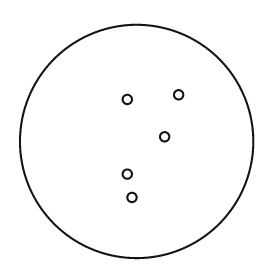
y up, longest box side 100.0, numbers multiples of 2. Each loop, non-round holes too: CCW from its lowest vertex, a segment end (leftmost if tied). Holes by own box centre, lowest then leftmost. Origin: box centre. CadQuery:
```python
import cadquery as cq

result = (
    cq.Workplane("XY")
    .moveTo(0.0, 0.0)
    .circle(50.0)
    .moveTo(-2.0, -24.0)
    .circle(2.0)
    .moveTo(-4.0, -14.0)
    .circle(2.0)
    .moveTo(12.0, 2.0)
    .circle(2.0)
    .moveTo(-4.0, 18.0)
    .circle(2.0)
    .moveTo(18.0, 20.0)
    .circle(2.0)
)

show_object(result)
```